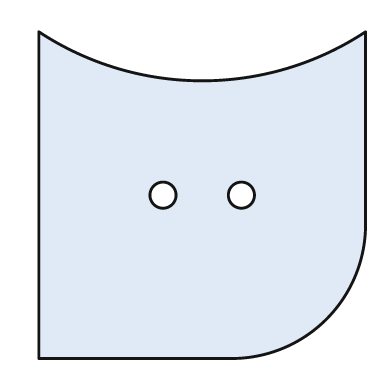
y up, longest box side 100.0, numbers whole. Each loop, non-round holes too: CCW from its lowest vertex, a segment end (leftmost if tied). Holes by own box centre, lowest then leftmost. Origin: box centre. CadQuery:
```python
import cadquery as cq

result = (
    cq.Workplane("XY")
    .moveTo(-50.0, -50.0)
    .lineTo(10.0, -50.0)
    .threePointArc((38.0, -38.0), (50.0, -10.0))
    .lineTo(50.0, 50.0)
    .threePointArc((0.0, 35.0), (-50.0, 50.0))
    .close()
    .moveTo(-12.0, 0.0)
    .circle(4.0)
    .moveTo(12.0, 0.0)
    .circle(4.0)
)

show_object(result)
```